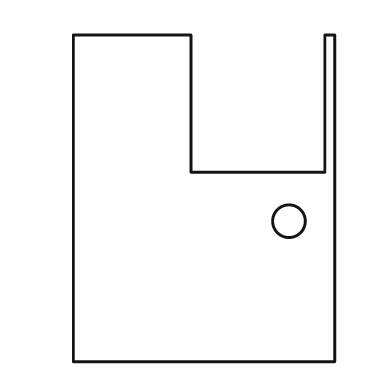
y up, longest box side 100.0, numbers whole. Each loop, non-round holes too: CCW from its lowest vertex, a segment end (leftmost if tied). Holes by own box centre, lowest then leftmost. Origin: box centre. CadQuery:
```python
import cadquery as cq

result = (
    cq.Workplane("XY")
    .moveTo(-40.0, -50.0)
    .lineTo(40.0, -50.0)
    .lineTo(40.0, 50.0)
    .lineTo(37.0, 50.0)
    .lineTo(37.0, 8.0)
    .lineTo(-4.0, 8.0)
    .lineTo(-4.0, 50.0)
    .lineTo(-40.0, 50.0)
    .close()
    .moveTo(26.0, -7.0)
    .circle(5.0)
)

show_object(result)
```